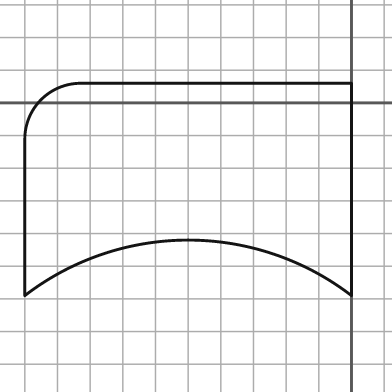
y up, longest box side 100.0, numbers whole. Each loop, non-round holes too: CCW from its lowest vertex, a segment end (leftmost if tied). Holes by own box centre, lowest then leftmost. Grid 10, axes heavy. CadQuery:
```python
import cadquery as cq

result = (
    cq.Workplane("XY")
    .moveTo(-100.0, -59.0)
    .threePointArc((-50.0, -42.0), (0.0, -59.0))
    .lineTo(0.0, 6.0)
    .lineTo(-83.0, 6.0)
    .threePointArc((-95.0, 1.0), (-100.0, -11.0))
    .close()
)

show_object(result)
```